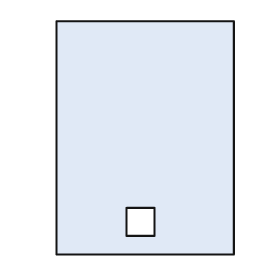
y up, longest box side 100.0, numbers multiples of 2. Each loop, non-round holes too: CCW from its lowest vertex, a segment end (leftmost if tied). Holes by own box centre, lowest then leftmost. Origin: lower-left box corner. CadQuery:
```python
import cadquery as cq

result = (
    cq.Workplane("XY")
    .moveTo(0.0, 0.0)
    .lineTo(76.0, 0.0)
    .lineTo(76.0, 100.0)
    .lineTo(0.0, 100.0)
    .close()
    .moveTo(30.0, 8.0)
    .lineTo(42.0, 8.0)
    .lineTo(42.0, 20.0)
    .lineTo(30.0, 20.0)
    .close()
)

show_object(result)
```